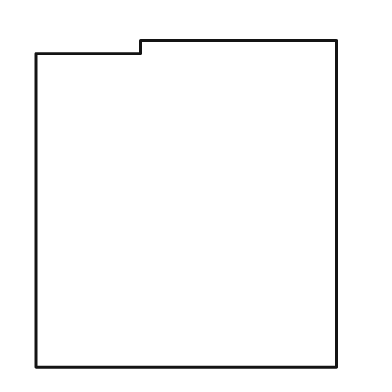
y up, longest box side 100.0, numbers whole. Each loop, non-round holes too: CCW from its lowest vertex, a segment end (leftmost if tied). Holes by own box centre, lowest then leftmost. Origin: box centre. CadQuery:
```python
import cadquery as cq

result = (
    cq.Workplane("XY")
    .moveTo(-46.0, -50.0)
    .lineTo(46.0, -50.0)
    .lineTo(46.0, 50.0)
    .lineTo(-14.0, 50.0)
    .lineTo(-14.0, 46.0)
    .lineTo(-46.0, 46.0)
    .close()
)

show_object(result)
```